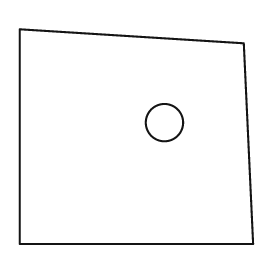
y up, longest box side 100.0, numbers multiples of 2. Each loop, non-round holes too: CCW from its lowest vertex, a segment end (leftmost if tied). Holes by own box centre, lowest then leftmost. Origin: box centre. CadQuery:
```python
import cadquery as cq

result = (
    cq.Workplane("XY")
    .moveTo(-50.0, -46.0)
    .lineTo(50.0, -46.0)
    .lineTo(46.0, 40.0)
    .lineTo(-50.0, 46.0)
    .close()
    .moveTo(12.0, 6.0)
    .circle(8.0)
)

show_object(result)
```